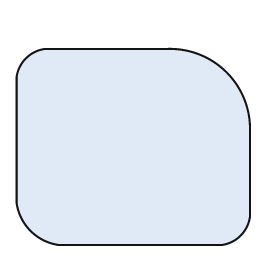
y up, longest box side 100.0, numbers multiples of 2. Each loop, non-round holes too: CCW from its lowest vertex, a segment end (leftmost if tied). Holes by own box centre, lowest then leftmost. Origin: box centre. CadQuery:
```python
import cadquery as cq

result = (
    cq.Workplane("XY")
    .moveTo(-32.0, -42.0)
    .lineTo(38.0, -42.0)
    .threePointArc((46.0, -38.0), (50.0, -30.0))
    .lineTo(50.0, 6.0)
    .threePointArc((40.0, 32.0), (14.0, 42.0))
    .lineTo(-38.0, 42.0)
    .threePointArc((-46.0, 38.0), (-50.0, 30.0))
    .lineTo(-50.0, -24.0)
    .threePointArc((-44.0, -36.0), (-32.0, -42.0))
    .close()
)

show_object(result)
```